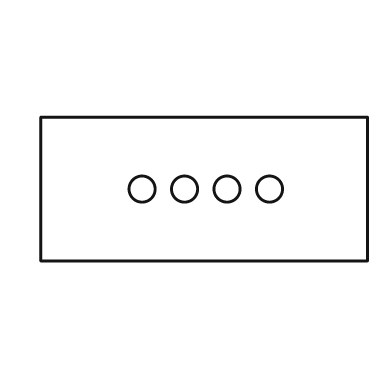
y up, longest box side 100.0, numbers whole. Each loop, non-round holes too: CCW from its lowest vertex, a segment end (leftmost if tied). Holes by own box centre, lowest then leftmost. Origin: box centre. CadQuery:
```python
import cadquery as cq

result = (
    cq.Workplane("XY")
    .moveTo(-50.0, -22.0)
    .lineTo(50.0, -22.0)
    .lineTo(50.0, 22.0)
    .lineTo(-50.0, 22.0)
    .close()
    .moveTo(-19.0, 0.0)
    .circle(4.0)
    .moveTo(-6.0, 0.0)
    .circle(4.0)
    .moveTo(7.0, 0.0)
    .circle(4.0)
    .moveTo(20.0, 0.0)
    .circle(4.0)
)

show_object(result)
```